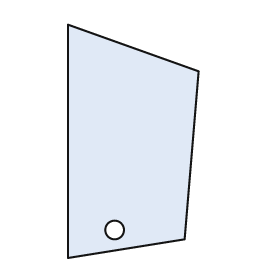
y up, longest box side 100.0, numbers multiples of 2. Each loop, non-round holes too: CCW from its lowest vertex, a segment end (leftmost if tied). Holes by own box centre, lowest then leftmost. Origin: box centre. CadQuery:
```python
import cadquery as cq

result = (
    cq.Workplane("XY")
    .moveTo(-28.0, -50.0)
    .lineTo(22.0, -42.0)
    .lineTo(28.0, 30.0)
    .lineTo(-28.0, 50.0)
    .close()
    .moveTo(-8.0, -38.0)
    .circle(4.0)
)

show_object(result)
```